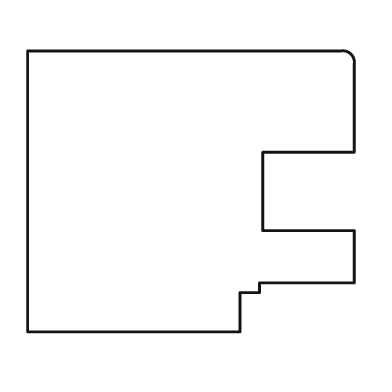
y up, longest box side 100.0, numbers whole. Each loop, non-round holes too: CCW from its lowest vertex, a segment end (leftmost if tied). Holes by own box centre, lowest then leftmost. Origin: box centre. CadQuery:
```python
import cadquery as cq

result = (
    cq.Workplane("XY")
    .moveTo(-50.0, -43.0)
    .lineTo(15.0, -43.0)
    .lineTo(15.0, -31.0)
    .lineTo(21.0, -31.0)
    .lineTo(21.0, -28.0)
    .lineTo(50.0, -28.0)
    .lineTo(50.0, -12.0)
    .lineTo(22.0, -12.0)
    .lineTo(22.0, 12.0)
    .lineTo(50.0, 12.0)
    .lineTo(50.0, 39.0)
    .threePointArc((49.0, 42.0), (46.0, 43.0))
    .lineTo(-50.0, 43.0)
    .close()
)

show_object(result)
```